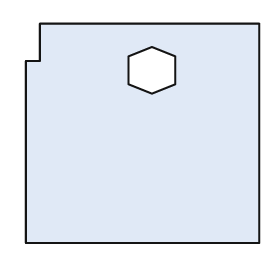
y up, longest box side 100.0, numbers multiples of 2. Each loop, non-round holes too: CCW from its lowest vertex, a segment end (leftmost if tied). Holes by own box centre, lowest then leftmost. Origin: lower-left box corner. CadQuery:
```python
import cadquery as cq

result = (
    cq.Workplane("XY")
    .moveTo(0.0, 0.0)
    .lineTo(100.0, 0.0)
    .lineTo(100.0, 94.0)
    .lineTo(6.0, 94.0)
    .lineTo(6.0, 78.0)
    .lineTo(0.0, 78.0)
    .close()
    .moveTo(54.0, 64.0)
    .lineTo(64.0, 68.0)
    .lineTo(64.0, 80.0)
    .lineTo(54.0, 84.0)
    .lineTo(44.0, 80.0)
    .lineTo(44.0, 68.0)
    .close()
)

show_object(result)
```